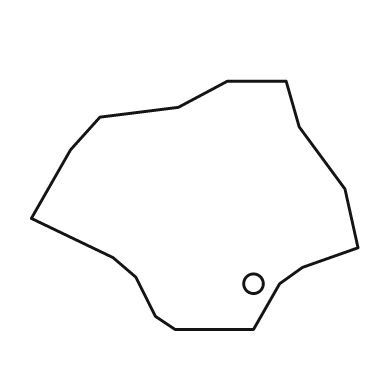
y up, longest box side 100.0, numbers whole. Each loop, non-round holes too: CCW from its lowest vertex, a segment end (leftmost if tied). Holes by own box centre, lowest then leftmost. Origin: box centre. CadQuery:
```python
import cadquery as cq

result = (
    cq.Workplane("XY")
    .moveTo(-6.0, -38.0)
    .lineTo(18.0, -38.0)
    .lineTo(26.0, -24.0)
    .lineTo(33.0, -19.0)
    .lineTo(50.0, -13.0)
    .lineTo(46.0, 5.0)
    .lineTo(32.0, 24.0)
    .lineTo(28.0, 38.0)
    .lineTo(10.0, 38.0)
    .lineTo(-5.0, 30.0)
    .lineTo(-29.0, 27.0)
    .lineTo(-38.0, 17.0)
    .lineTo(-50.0, -4.0)
    .lineTo(-25.0, -16.0)
    .lineTo(-18.0, -22.0)
    .lineTo(-12.0, -34.0)
    .close()
    .moveTo(18.0, -24.0)
    .circle(3.0)
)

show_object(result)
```